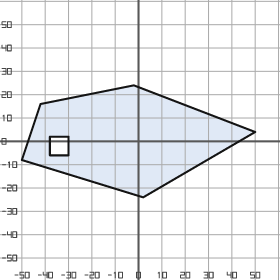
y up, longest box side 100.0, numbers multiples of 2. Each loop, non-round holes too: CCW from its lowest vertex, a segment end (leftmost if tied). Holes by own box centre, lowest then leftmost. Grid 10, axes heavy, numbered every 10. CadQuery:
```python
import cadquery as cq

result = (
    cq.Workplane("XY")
    .moveTo(2.0, -24.0)
    .lineTo(50.0, 4.0)
    .lineTo(-2.0, 24.0)
    .lineTo(-42.0, 16.0)
    .lineTo(-50.0, -8.0)
    .close()
    .moveTo(-38.0, -6.0)
    .lineTo(-30.0, -6.0)
    .lineTo(-30.0, 2.0)
    .lineTo(-38.0, 2.0)
    .close()
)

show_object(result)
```